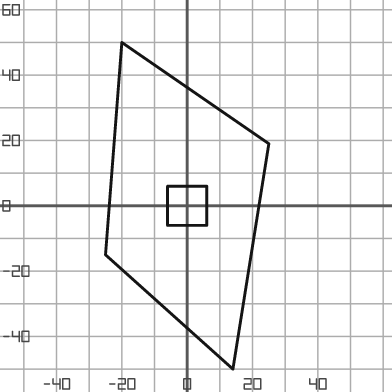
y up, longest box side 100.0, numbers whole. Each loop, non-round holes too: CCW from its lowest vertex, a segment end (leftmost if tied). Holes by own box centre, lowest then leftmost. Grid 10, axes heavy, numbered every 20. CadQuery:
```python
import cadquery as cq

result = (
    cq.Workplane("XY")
    .moveTo(14.0, -50.0)
    .lineTo(25.0, 19.0)
    .lineTo(-20.0, 50.0)
    .lineTo(-25.0, -15.0)
    .close()
    .moveTo(-6.0, -6.0)
    .lineTo(6.0, -6.0)
    .lineTo(6.0, 6.0)
    .lineTo(-6.0, 6.0)
    .close()
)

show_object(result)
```